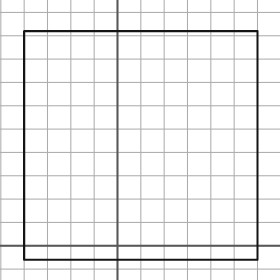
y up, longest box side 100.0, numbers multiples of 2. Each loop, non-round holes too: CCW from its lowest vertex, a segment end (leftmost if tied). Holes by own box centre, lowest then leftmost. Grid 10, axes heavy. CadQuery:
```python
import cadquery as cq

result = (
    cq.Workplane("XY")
    .moveTo(-40.0, -6.0)
    .lineTo(60.0, -6.0)
    .lineTo(60.0, 92.0)
    .lineTo(-40.0, 92.0)
    .close()
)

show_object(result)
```